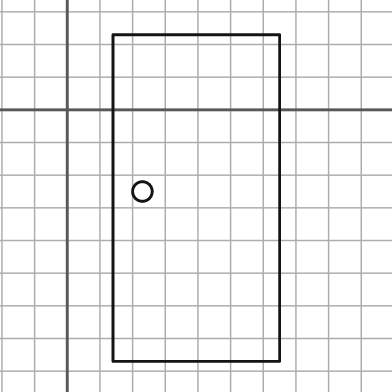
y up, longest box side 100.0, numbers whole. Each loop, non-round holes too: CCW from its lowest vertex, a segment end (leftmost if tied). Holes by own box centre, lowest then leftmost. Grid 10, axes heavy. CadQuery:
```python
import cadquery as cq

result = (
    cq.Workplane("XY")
    .moveTo(14.0, -77.0)
    .lineTo(65.0, -77.0)
    .lineTo(65.0, 23.0)
    .lineTo(14.0, 23.0)
    .close()
    .moveTo(23.0, -25.0)
    .circle(3.0)
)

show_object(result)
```